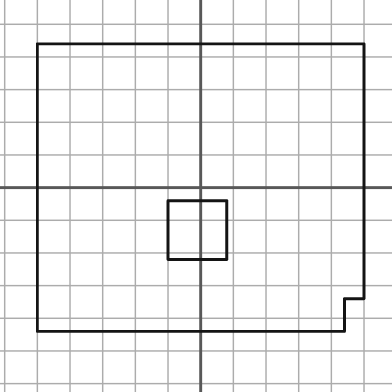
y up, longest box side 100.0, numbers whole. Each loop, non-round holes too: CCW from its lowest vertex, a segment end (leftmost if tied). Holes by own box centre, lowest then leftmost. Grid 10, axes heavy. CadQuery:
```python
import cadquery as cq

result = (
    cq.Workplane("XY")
    .moveTo(-50.0, -44.0)
    .lineTo(44.0, -44.0)
    .lineTo(44.0, -34.0)
    .lineTo(50.0, -34.0)
    .lineTo(50.0, 44.0)
    .lineTo(-50.0, 44.0)
    .close()
    .moveTo(-10.0, -22.0)
    .lineTo(8.0, -22.0)
    .lineTo(8.0, -4.0)
    .lineTo(-10.0, -4.0)
    .close()
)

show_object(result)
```